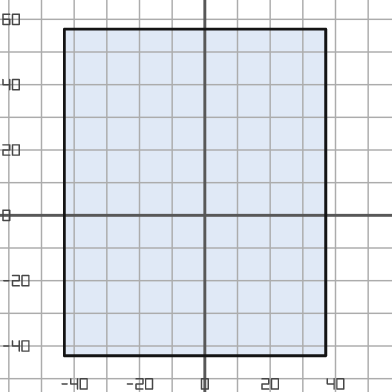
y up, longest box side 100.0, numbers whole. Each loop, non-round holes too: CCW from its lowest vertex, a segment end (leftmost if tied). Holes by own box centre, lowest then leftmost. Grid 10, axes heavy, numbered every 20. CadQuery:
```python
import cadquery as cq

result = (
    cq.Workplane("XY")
    .moveTo(-43.0, -43.0)
    .lineTo(37.0, -43.0)
    .lineTo(37.0, 57.0)
    .lineTo(-43.0, 57.0)
    .close()
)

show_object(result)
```